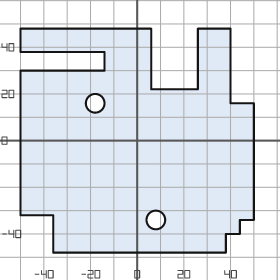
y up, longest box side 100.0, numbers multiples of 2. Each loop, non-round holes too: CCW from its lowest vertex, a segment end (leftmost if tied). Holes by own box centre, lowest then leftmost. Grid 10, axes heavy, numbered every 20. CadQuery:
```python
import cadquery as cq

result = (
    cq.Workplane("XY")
    .moveTo(-36.0, -48.0)
    .lineTo(38.0, -48.0)
    .lineTo(38.0, -40.0)
    .lineTo(44.0, -40.0)
    .lineTo(44.0, -34.0)
    .lineTo(50.0, -34.0)
    .lineTo(50.0, 16.0)
    .lineTo(40.0, 16.0)
    .lineTo(40.0, 48.0)
    .lineTo(26.0, 48.0)
    .lineTo(26.0, 22.0)
    .lineTo(6.0, 22.0)
    .lineTo(6.0, 48.0)
    .lineTo(-50.0, 48.0)
    .lineTo(-50.0, 38.0)
    .lineTo(-14.0, 38.0)
    .lineTo(-14.0, 30.0)
    .lineTo(-50.0, 30.0)
    .lineTo(-50.0, -32.0)
    .lineTo(-36.0, -32.0)
    .close()
    .moveTo(8.0, -34.0)
    .circle(4.0)
    .moveTo(-18.0, 16.0)
    .circle(4.0)
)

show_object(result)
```